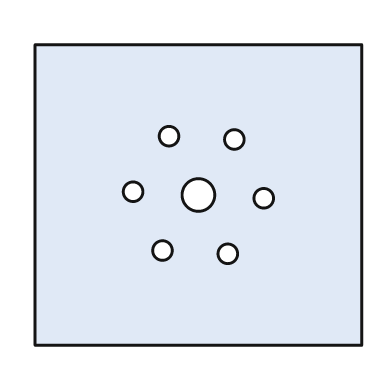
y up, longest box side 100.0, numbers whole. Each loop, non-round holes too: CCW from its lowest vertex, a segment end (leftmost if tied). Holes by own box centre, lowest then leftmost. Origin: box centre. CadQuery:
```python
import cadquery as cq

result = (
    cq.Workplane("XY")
    .moveTo(-50.0, -46.0)
    .lineTo(50.0, -46.0)
    .lineTo(50.0, 46.0)
    .lineTo(-50.0, 46.0)
    .close()
    .moveTo(9.0, -18.0)
    .circle(3.0)
    .moveTo(-11.0, -17.0)
    .circle(3.0)
    .moveTo(20.0, -1.0)
    .circle(3.0)
    .moveTo(0.0, 0.0)
    .circle(5.0)
    .moveTo(-20.0, 1.0)
    .circle(3.0)
    .moveTo(11.0, 17.0)
    .circle(3.0)
    .moveTo(-9.0, 18.0)
    .circle(3.0)
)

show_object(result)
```